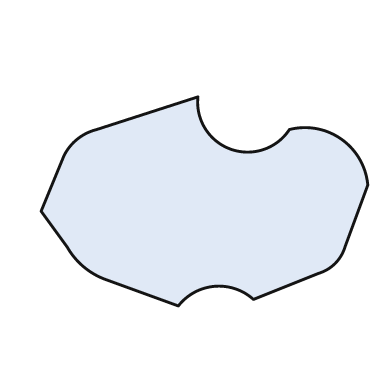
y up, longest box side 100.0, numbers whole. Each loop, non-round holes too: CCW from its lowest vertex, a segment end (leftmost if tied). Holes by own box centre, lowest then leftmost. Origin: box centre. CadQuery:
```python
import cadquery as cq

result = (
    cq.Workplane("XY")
    .moveTo(-8.0, -32.0)
    .threePointArc((3.0, -26.0), (15.0, -30.0))
    .lineTo(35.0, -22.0)
    .threePointArc((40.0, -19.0), (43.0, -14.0))
    .lineTo(50.0, 5.0)
    .threePointArc((42.0, 19.0), (26.0, 22.0))
    .threePointArc((8.0, 16.0), (-2.0, 32.0))
    .lineTo(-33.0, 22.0)
    .threePointArc((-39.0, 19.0), (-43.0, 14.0))
    .lineTo(-50.0, -3.0)
    .lineTo(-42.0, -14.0)
    .threePointArc((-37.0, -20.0), (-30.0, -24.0))
    .close()
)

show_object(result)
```